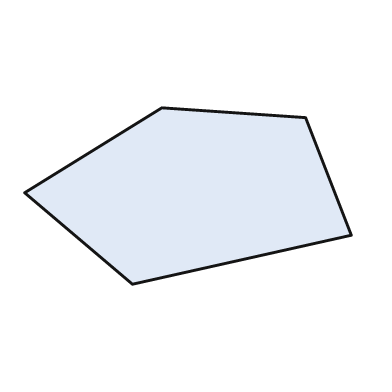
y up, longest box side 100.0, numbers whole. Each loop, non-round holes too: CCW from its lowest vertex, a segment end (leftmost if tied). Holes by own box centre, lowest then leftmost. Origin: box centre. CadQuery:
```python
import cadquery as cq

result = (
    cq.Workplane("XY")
    .moveTo(-17.0, -27.0)
    .lineTo(50.0, -12.0)
    .lineTo(36.0, 24.0)
    .lineTo(-8.0, 27.0)
    .lineTo(-50.0, 1.0)
    .close()
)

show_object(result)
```